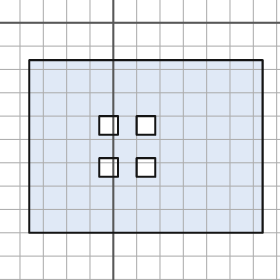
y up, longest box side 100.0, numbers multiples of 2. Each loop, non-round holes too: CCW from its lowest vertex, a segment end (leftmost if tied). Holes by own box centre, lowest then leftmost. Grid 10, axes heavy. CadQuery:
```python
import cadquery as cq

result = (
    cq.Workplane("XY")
    .moveTo(-36.0, -90.0)
    .lineTo(64.0, -90.0)
    .lineTo(64.0, -16.0)
    .lineTo(-36.0, -16.0)
    .close()
    .moveTo(-6.0, -66.0)
    .lineTo(2.0, -66.0)
    .lineTo(2.0, -58.0)
    .lineTo(-6.0, -58.0)
    .close()
    .moveTo(10.0, -66.0)
    .lineTo(18.0, -66.0)
    .lineTo(18.0, -58.0)
    .lineTo(10.0, -58.0)
    .close()
    .moveTo(-6.0, -48.0)
    .lineTo(2.0, -48.0)
    .lineTo(2.0, -40.0)
    .lineTo(-6.0, -40.0)
    .close()
    .moveTo(10.0, -48.0)
    .lineTo(18.0, -48.0)
    .lineTo(18.0, -40.0)
    .lineTo(10.0, -40.0)
    .close()
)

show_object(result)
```